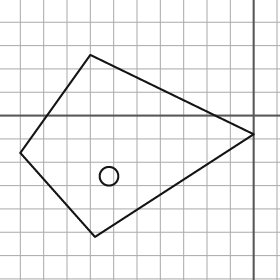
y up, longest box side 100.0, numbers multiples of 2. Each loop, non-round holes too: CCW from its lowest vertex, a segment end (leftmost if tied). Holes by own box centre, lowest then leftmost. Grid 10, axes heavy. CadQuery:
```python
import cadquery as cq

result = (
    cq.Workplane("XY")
    .moveTo(-68.0, -52.0)
    .lineTo(0.0, -8.0)
    .lineTo(-70.0, 26.0)
    .lineTo(-100.0, -16.0)
    .close()
    .moveTo(-62.0, -26.0)
    .circle(4.0)
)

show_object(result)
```